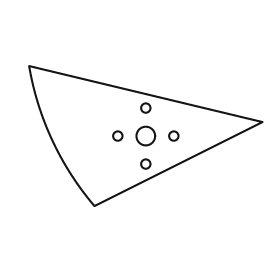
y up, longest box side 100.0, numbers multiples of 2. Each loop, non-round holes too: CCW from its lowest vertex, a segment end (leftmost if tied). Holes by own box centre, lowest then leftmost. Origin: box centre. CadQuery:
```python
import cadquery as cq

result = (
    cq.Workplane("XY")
    .moveTo(-22.0, -30.0)
    .lineTo(50.0, 6.0)
    .lineTo(-50.0, 30.0)
    .threePointArc((-40.0, -2.0), (-22.0, -30.0))
    .close()
    .moveTo(0.0, -12.0)
    .circle(2.0)
    .moveTo(-12.0, 0.0)
    .circle(2.0)
    .moveTo(0.0, 0.0)
    .circle(4.0)
    .moveTo(12.0, 0.0)
    .circle(2.0)
    .moveTo(0.0, 12.0)
    .circle(2.0)
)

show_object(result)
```